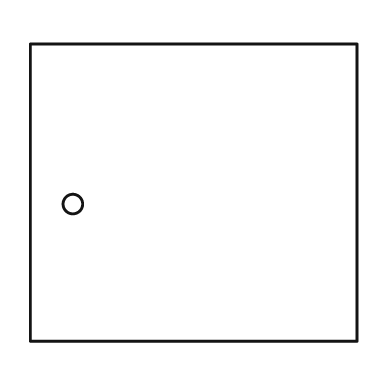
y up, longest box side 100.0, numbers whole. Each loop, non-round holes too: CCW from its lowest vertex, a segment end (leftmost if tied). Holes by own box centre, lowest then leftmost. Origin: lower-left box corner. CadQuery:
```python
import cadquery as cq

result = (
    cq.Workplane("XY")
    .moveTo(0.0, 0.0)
    .lineTo(100.0, 0.0)
    .lineTo(100.0, 91.0)
    .lineTo(0.0, 91.0)
    .close()
    .moveTo(13.0, 42.0)
    .circle(3.0)
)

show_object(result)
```